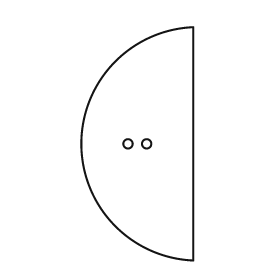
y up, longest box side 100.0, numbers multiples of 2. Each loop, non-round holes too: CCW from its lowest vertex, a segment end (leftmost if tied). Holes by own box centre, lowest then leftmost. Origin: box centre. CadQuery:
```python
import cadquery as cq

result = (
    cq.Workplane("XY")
    .moveTo(24.0, -50.0)
    .lineTo(24.0, 50.0)
    .threePointArc((-24.0, 0.0), (24.0, -50.0))
    .close()
    .moveTo(-4.0, 0.0)
    .circle(2.0)
    .moveTo(4.0, 0.0)
    .circle(2.0)
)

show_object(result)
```